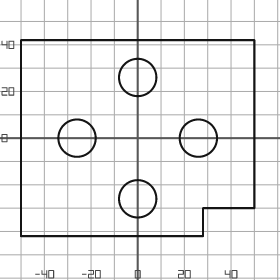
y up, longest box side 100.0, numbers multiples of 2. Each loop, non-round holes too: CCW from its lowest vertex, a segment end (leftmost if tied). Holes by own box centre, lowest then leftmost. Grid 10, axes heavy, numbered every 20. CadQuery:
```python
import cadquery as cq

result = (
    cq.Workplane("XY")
    .moveTo(-50.0, -42.0)
    .lineTo(28.0, -42.0)
    .lineTo(28.0, -30.0)
    .lineTo(50.0, -30.0)
    .lineTo(50.0, 42.0)
    .lineTo(-50.0, 42.0)
    .close()
    .moveTo(0.0, -26.0)
    .circle(8.0)
    .moveTo(-26.0, 0.0)
    .circle(8.0)
    .moveTo(26.0, 0.0)
    .circle(8.0)
    .moveTo(0.0, 26.0)
    .circle(8.0)
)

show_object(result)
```